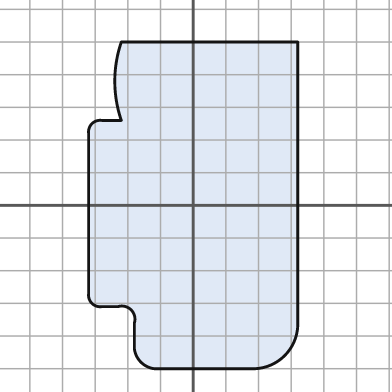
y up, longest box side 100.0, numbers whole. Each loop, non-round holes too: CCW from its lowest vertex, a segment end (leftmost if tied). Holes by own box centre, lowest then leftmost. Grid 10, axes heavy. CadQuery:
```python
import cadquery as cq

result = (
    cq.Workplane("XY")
    .moveTo(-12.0, -50.0)
    .lineTo(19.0, -50.0)
    .threePointArc((28.0, -46.0), (32.0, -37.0))
    .lineTo(32.0, 50.0)
    .lineTo(-22.0, 50.0)
    .threePointArc((-24.0, 38.0), (-22.0, 26.0))
    .lineTo(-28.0, 26.0)
    .threePointArc((-31.0, 25.0), (-32.0, 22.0))
    .lineTo(-32.0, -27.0)
    .threePointArc((-31.0, -30.0), (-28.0, -31.0))
    .lineTo(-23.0, -31.0)
    .threePointArc((-19.0, -32.0), (-18.0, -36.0))
    .lineTo(-18.0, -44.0)
    .threePointArc((-16.0, -48.0), (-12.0, -50.0))
    .close()
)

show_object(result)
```